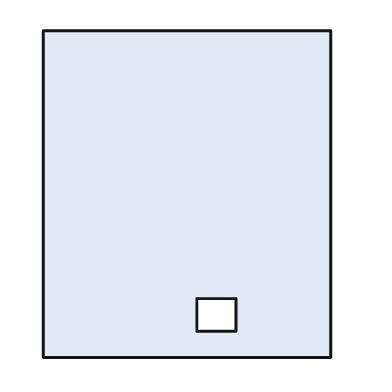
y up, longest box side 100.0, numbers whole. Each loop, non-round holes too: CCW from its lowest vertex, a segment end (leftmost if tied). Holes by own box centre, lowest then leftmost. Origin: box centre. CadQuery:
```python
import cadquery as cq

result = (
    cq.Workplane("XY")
    .moveTo(-44.0, -50.0)
    .lineTo(44.0, -50.0)
    .lineTo(44.0, 50.0)
    .lineTo(-44.0, 50.0)
    .close()
    .moveTo(3.0, -42.0)
    .lineTo(15.0, -42.0)
    .lineTo(15.0, -32.0)
    .lineTo(3.0, -32.0)
    .close()
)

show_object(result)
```